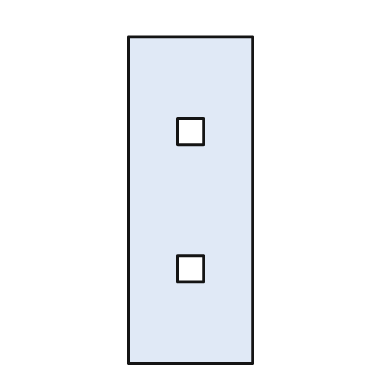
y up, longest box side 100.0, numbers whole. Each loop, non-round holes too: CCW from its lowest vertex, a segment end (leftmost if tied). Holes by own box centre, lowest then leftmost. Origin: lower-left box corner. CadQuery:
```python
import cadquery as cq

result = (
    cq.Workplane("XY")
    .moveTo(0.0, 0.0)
    .lineTo(38.0, 0.0)
    .lineTo(38.0, 100.0)
    .lineTo(0.0, 100.0)
    .close()
    .moveTo(15.0, 25.0)
    .lineTo(23.0, 25.0)
    .lineTo(23.0, 33.0)
    .lineTo(15.0, 33.0)
    .close()
    .moveTo(15.0, 67.0)
    .lineTo(23.0, 67.0)
    .lineTo(23.0, 75.0)
    .lineTo(15.0, 75.0)
    .close()
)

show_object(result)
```